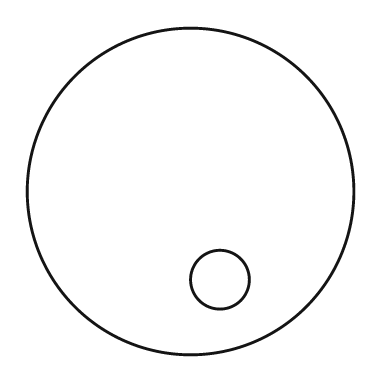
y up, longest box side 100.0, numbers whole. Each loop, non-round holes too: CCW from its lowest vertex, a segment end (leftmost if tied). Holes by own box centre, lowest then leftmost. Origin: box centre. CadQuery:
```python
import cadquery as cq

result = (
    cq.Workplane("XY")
    .moveTo(0.0, 0.0)
    .circle(50.0)
    .moveTo(9.0, -27.0)
    .circle(9.0)
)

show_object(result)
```